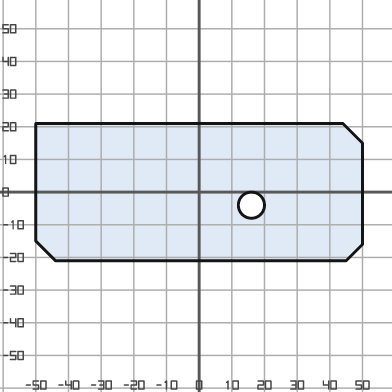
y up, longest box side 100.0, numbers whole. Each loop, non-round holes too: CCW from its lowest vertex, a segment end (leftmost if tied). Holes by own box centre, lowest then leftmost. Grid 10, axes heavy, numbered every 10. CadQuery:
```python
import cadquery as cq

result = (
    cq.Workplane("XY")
    .moveTo(-44.0, -21.0)
    .lineTo(45.0, -21.0)
    .lineTo(50.0, -16.0)
    .lineTo(50.0, 15.0)
    .lineTo(44.0, 21.0)
    .lineTo(-50.0, 21.0)
    .lineTo(-50.0, -15.0)
    .close()
    .moveTo(16.0, -4.0)
    .circle(4.0)
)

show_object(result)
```